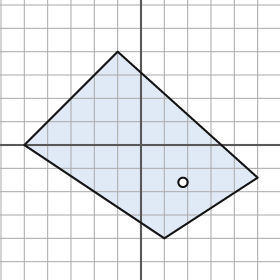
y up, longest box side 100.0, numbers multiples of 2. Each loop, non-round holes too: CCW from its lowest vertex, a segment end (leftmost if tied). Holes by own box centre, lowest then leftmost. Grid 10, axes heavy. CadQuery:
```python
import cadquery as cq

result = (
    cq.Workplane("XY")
    .moveTo(10.0, -40.0)
    .lineTo(50.0, -14.0)
    .lineTo(-10.0, 40.0)
    .lineTo(-50.0, 0.0)
    .close()
    .moveTo(18.0, -16.0)
    .circle(2.0)
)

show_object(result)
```